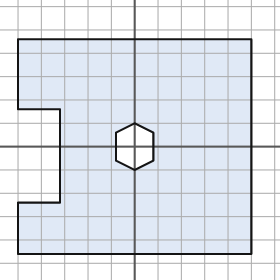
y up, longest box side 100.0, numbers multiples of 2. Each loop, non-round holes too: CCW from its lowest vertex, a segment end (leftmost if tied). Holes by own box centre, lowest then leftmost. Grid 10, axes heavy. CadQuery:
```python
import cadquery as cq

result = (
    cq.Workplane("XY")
    .moveTo(-50.0, -46.0)
    .lineTo(50.0, -46.0)
    .lineTo(50.0, 46.0)
    .lineTo(-50.0, 46.0)
    .lineTo(-50.0, 16.0)
    .lineTo(-32.0, 16.0)
    .lineTo(-32.0, -24.0)
    .lineTo(-50.0, -24.0)
    .close()
    .moveTo(0.0, -10.0)
    .lineTo(8.0, -6.0)
    .lineTo(8.0, 6.0)
    .lineTo(0.0, 10.0)
    .lineTo(-8.0, 6.0)
    .lineTo(-8.0, -6.0)
    .close()
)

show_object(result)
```